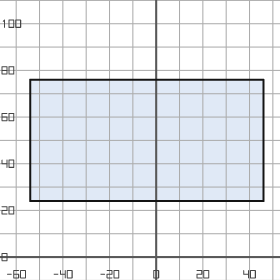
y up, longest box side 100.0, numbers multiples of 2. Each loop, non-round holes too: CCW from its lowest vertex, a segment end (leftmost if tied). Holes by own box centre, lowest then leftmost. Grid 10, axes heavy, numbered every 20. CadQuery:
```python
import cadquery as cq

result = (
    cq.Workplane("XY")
    .moveTo(-54.0, 24.0)
    .lineTo(46.0, 24.0)
    .lineTo(46.0, 76.0)
    .lineTo(-54.0, 76.0)
    .close()
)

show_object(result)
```